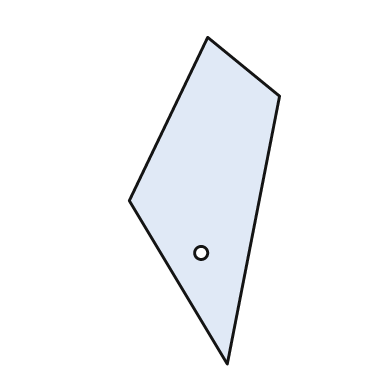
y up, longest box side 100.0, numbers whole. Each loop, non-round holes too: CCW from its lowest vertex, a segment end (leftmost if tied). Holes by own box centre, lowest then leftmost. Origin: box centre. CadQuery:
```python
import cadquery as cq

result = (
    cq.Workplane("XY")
    .moveTo(7.0, -50.0)
    .lineTo(23.0, 32.0)
    .lineTo(1.0, 50.0)
    .lineTo(-23.0, 0.0)
    .close()
    .moveTo(-1.0, -16.0)
    .circle(2.0)
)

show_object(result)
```